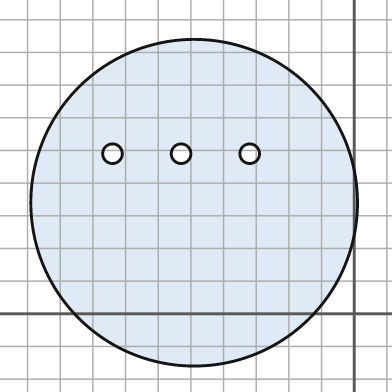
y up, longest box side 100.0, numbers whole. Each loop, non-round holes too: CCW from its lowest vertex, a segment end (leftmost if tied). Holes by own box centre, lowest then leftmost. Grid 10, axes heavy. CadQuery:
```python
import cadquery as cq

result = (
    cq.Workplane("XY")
    .moveTo(-49.0, 34.0)
    .circle(50.0)
    .moveTo(-74.0, 49.0)
    .circle(3.0)
    .moveTo(-53.0, 49.0)
    .circle(3.0)
    .moveTo(-32.0, 49.0)
    .circle(3.0)
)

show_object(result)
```